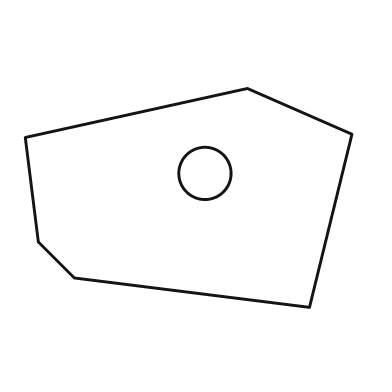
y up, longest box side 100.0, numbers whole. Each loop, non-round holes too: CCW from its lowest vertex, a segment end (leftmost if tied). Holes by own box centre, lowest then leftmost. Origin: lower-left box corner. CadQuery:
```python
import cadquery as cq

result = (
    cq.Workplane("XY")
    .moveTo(87.0, 0.0)
    .lineTo(100.0, 53.0)
    .lineTo(68.0, 67.0)
    .lineTo(0.0, 52.0)
    .lineTo(4.0, 20.0)
    .lineTo(15.0, 9.0)
    .close()
    .moveTo(55.0, 41.0)
    .circle(8.0)
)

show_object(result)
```